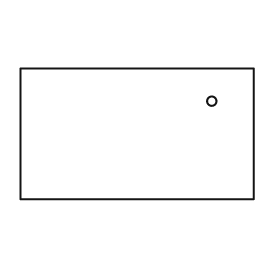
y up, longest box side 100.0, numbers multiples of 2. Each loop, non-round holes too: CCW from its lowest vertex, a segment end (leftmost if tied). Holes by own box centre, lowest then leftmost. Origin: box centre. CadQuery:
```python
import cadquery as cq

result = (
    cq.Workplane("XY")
    .moveTo(-50.0, -28.0)
    .lineTo(50.0, -28.0)
    .lineTo(50.0, 28.0)
    .lineTo(-50.0, 28.0)
    .close()
    .moveTo(32.0, 14.0)
    .circle(2.0)
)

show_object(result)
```